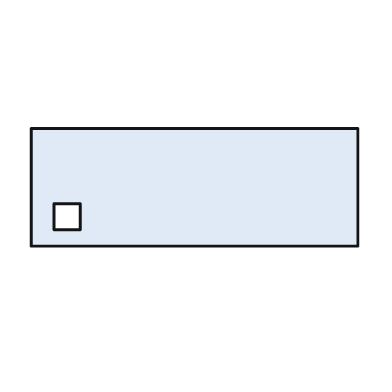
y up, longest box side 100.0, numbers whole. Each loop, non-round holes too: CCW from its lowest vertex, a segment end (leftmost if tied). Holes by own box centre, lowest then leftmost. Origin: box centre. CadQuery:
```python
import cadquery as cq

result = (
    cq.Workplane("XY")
    .moveTo(-50.0, -18.0)
    .lineTo(50.0, -18.0)
    .lineTo(50.0, 18.0)
    .lineTo(-50.0, 18.0)
    .close()
    .moveTo(-43.0, -13.0)
    .lineTo(-35.0, -13.0)
    .lineTo(-35.0, -5.0)
    .lineTo(-43.0, -5.0)
    .close()
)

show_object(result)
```